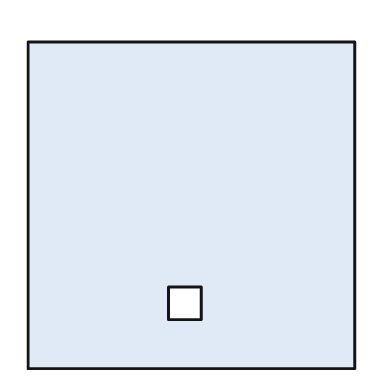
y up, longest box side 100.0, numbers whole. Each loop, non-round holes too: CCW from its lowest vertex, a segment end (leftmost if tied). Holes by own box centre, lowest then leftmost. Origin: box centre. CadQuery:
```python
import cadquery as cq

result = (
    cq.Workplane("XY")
    .moveTo(-50.0, -50.0)
    .lineTo(50.0, -50.0)
    .lineTo(50.0, 50.0)
    .lineTo(-50.0, 50.0)
    .close()
    .moveTo(-7.0, -35.0)
    .lineTo(3.0, -35.0)
    .lineTo(3.0, -25.0)
    .lineTo(-7.0, -25.0)
    .close()
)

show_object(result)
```